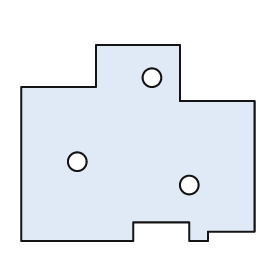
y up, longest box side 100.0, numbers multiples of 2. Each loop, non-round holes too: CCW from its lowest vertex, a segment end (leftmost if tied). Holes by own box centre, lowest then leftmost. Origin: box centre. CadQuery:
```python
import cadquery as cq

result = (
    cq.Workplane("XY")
    .moveTo(-50.0, -42.0)
    .lineTo(-2.0, -42.0)
    .lineTo(-2.0, -34.0)
    .lineTo(22.0, -34.0)
    .lineTo(22.0, -42.0)
    .lineTo(30.0, -42.0)
    .lineTo(30.0, -38.0)
    .lineTo(50.0, -38.0)
    .lineTo(50.0, 18.0)
    .lineTo(18.0, 18.0)
    .lineTo(18.0, 42.0)
    .lineTo(-18.0, 42.0)
    .lineTo(-18.0, 24.0)
    .lineTo(-50.0, 24.0)
    .close()
    .moveTo(22.0, -18.0)
    .circle(4.0)
    .moveTo(-26.0, -8.0)
    .circle(4.0)
    .moveTo(6.0, 28.0)
    .circle(4.0)
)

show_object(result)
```